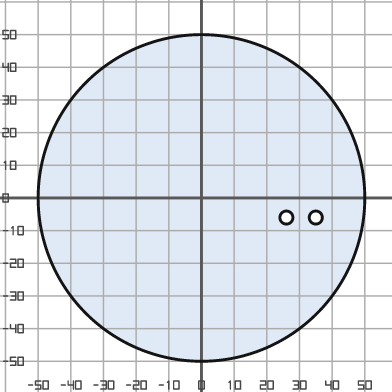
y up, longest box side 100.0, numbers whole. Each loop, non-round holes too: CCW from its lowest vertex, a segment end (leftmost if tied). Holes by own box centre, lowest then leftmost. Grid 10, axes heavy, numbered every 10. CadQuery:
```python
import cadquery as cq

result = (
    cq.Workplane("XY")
    .moveTo(0.0, 0.0)
    .circle(50.0)
    .moveTo(26.0, -6.0)
    .circle(2.0)
    .moveTo(35.0, -6.0)
    .circle(2.0)
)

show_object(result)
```